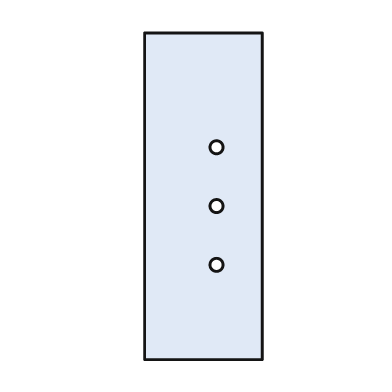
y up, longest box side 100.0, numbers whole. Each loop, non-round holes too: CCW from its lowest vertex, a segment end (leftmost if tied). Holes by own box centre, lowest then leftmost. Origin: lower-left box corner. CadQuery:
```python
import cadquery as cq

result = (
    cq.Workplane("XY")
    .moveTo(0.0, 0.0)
    .lineTo(36.0, 0.0)
    .lineTo(36.0, 100.0)
    .lineTo(0.0, 100.0)
    .close()
    .moveTo(22.0, 29.0)
    .circle(2.0)
    .moveTo(22.0, 47.0)
    .circle(2.0)
    .moveTo(22.0, 65.0)
    .circle(2.0)
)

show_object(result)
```